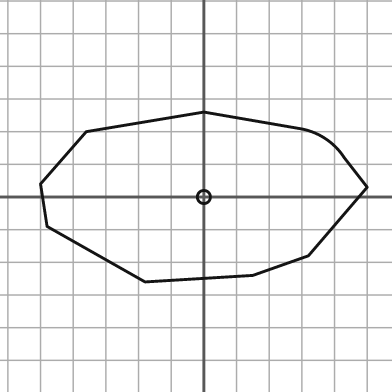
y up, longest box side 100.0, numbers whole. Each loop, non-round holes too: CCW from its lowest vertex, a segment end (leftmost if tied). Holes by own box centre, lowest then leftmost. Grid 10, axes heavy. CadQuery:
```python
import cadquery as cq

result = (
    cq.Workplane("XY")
    .moveTo(-18.0, -26.0)
    .lineTo(15.0, -24.0)
    .lineTo(32.0, -18.0)
    .lineTo(50.0, 3.0)
    .lineTo(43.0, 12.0)
    .threePointArc((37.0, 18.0), (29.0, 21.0))
    .lineTo(0.0, 26.0)
    .lineTo(-36.0, 20.0)
    .lineTo(-50.0, 4.0)
    .lineTo(-48.0, -9.0)
    .close()
    .moveTo(0.0, 0.0)
    .circle(2.0)
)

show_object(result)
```